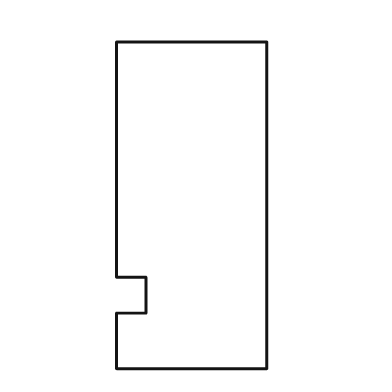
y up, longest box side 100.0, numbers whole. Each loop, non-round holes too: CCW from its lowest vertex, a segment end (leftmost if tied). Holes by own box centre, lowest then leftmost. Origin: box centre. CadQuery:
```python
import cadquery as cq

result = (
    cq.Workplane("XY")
    .moveTo(-23.0, -50.0)
    .lineTo(23.0, -50.0)
    .lineTo(23.0, 50.0)
    .lineTo(-23.0, 50.0)
    .lineTo(-23.0, -22.0)
    .lineTo(-14.0, -22.0)
    .lineTo(-14.0, -33.0)
    .lineTo(-23.0, -33.0)
    .close()
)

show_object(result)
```